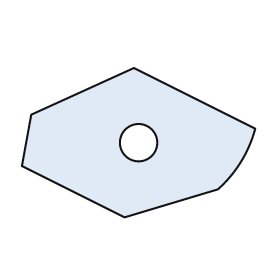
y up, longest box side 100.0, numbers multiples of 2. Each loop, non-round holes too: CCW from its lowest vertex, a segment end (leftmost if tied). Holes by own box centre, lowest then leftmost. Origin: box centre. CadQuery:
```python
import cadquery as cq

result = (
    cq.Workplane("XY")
    .moveTo(-6.0, -32.0)
    .lineTo(34.0, -20.0)
    .threePointArc((44.0, -8.0), (50.0, 6.0))
    .lineTo(-2.0, 32.0)
    .lineTo(-46.0, 12.0)
    .lineTo(-50.0, -10.0)
    .close()
    .moveTo(0.0, 0.0)
    .circle(8.0)
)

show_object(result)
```